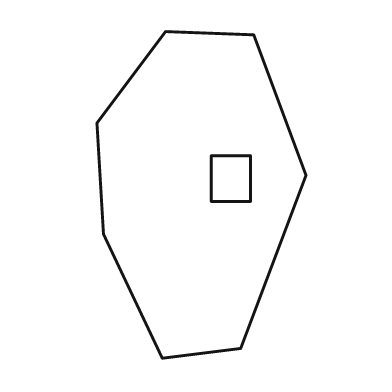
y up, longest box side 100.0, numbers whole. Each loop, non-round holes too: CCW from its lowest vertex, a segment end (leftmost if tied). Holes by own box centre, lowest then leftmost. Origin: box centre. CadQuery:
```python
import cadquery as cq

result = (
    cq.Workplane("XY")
    .moveTo(-12.0, -50.0)
    .lineTo(12.0, -47.0)
    .lineTo(32.0, 6.0)
    .lineTo(16.0, 49.0)
    .lineTo(-11.0, 50.0)
    .lineTo(-32.0, 22.0)
    .lineTo(-30.0, -12.0)
    .close()
    .moveTo(3.0, -2.0)
    .lineTo(15.0, -2.0)
    .lineTo(15.0, 12.0)
    .lineTo(3.0, 12.0)
    .close()
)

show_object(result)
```